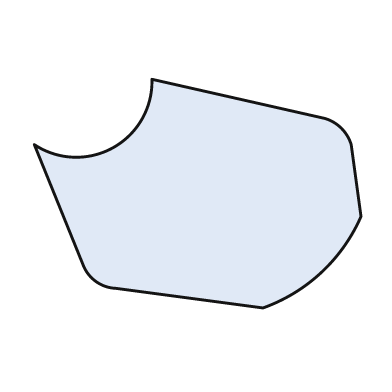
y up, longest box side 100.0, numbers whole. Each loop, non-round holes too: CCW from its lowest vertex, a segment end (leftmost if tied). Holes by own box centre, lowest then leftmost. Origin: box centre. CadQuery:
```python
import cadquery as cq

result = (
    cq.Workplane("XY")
    .moveTo(20.0, -35.0)
    .threePointArc((38.0, -24.0), (50.0, -7.0))
    .lineTo(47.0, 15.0)
    .threePointArc((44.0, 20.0), (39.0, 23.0))
    .lineTo(-14.0, 35.0)
    .threePointArc((-26.0, 14.0), (-50.0, 15.0))
    .lineTo(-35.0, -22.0)
    .threePointArc((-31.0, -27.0), (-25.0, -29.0))
    .close()
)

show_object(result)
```